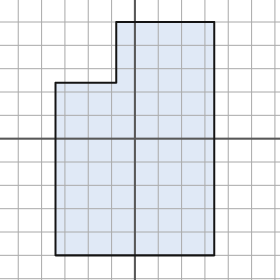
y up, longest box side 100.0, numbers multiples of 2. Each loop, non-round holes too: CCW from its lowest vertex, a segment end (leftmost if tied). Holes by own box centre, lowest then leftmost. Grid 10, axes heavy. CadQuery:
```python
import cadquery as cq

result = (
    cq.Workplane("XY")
    .moveTo(-34.0, -50.0)
    .lineTo(34.0, -50.0)
    .lineTo(34.0, 50.0)
    .lineTo(-8.0, 50.0)
    .lineTo(-8.0, 24.0)
    .lineTo(-34.0, 24.0)
    .close()
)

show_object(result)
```